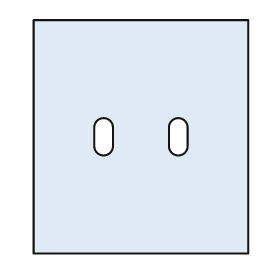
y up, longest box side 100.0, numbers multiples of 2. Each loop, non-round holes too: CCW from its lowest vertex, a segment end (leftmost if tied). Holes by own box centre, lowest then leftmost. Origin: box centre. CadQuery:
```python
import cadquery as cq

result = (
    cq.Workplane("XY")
    .moveTo(-46.0, -50.0)
    .lineTo(46.0, -50.0)
    .lineTo(46.0, 50.0)
    .lineTo(-46.0, 50.0)
    .close()
    .moveTo(-20.0, -4.0)
    .threePointArc((-16.0, -8.0), (-12.0, -4.0))
    .lineTo(-12.0, 4.0)
    .threePointArc((-16.0, 8.0), (-20.0, 4.0))
    .close()
    .moveTo(12.0, -4.0)
    .threePointArc((16.0, -8.0), (20.0, -4.0))
    .lineTo(20.0, 4.0)
    .threePointArc((16.0, 8.0), (12.0, 4.0))
    .close()
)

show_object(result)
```